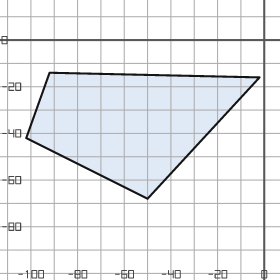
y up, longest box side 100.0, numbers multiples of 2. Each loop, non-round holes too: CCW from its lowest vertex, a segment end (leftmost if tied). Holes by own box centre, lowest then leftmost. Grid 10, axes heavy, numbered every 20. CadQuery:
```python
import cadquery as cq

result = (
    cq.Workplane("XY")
    .moveTo(-50.0, -68.0)
    .lineTo(-2.0, -16.0)
    .lineTo(-92.0, -14.0)
    .lineTo(-102.0, -42.0)
    .close()
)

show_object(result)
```